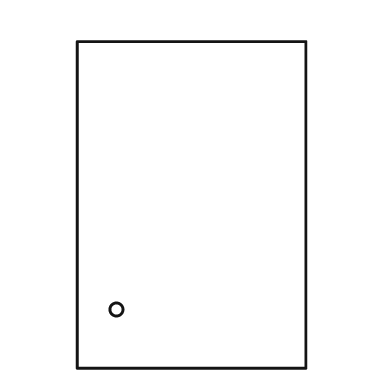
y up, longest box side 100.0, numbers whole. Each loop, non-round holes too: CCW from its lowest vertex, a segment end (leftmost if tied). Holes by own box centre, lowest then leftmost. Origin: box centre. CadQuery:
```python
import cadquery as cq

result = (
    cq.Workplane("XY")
    .moveTo(-35.0, -50.0)
    .lineTo(35.0, -50.0)
    .lineTo(35.0, 50.0)
    .lineTo(-35.0, 50.0)
    .close()
    .moveTo(-23.0, -32.0)
    .circle(2.0)
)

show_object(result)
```